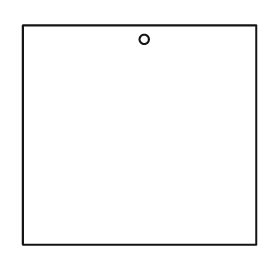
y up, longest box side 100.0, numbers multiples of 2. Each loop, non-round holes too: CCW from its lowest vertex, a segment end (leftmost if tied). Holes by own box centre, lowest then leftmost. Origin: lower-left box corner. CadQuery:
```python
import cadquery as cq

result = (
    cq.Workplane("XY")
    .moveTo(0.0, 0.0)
    .lineTo(100.0, 0.0)
    .lineTo(100.0, 94.0)
    .lineTo(0.0, 94.0)
    .close()
    .moveTo(52.0, 88.0)
    .circle(2.0)
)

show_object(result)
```